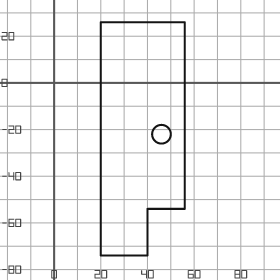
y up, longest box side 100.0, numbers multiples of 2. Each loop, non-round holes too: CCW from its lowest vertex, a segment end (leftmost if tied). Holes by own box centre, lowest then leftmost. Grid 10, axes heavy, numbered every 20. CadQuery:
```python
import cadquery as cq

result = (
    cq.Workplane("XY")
    .moveTo(20.0, -74.0)
    .lineTo(40.0, -74.0)
    .lineTo(40.0, -54.0)
    .lineTo(56.0, -54.0)
    .lineTo(56.0, 26.0)
    .lineTo(20.0, 26.0)
    .close()
    .moveTo(46.0, -22.0)
    .circle(4.0)
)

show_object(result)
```